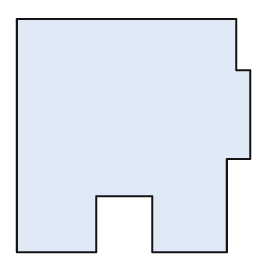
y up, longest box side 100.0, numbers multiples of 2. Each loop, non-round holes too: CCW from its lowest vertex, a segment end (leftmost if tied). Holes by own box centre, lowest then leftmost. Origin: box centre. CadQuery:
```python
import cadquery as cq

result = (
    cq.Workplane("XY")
    .moveTo(-50.0, -50.0)
    .lineTo(-16.0, -50.0)
    .lineTo(-16.0, -26.0)
    .lineTo(8.0, -26.0)
    .lineTo(8.0, -50.0)
    .lineTo(40.0, -50.0)
    .lineTo(40.0, -10.0)
    .lineTo(50.0, -10.0)
    .lineTo(50.0, 28.0)
    .lineTo(44.0, 28.0)
    .lineTo(44.0, 50.0)
    .lineTo(-50.0, 50.0)
    .close()
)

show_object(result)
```